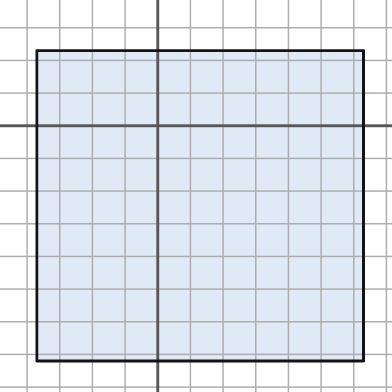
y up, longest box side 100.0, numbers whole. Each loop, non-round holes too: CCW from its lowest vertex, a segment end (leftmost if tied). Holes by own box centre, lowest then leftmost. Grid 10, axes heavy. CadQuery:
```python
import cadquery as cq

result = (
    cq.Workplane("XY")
    .moveTo(-37.0, -72.0)
    .lineTo(63.0, -72.0)
    .lineTo(63.0, 23.0)
    .lineTo(-37.0, 23.0)
    .close()
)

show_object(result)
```